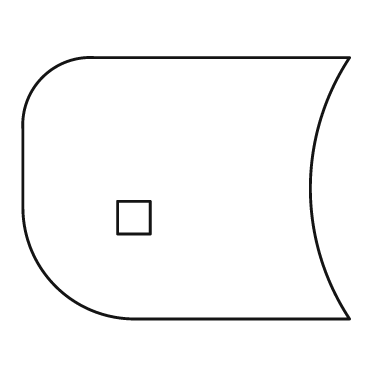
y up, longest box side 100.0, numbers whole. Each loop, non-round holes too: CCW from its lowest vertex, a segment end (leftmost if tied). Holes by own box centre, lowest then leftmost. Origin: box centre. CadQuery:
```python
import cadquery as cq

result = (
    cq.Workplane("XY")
    .moveTo(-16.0, -40.0)
    .lineTo(50.0, -40.0)
    .threePointArc((38.0, 0.0), (50.0, 40.0))
    .lineTo(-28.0, 40.0)
    .threePointArc((-44.0, 34.0), (-50.0, 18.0))
    .lineTo(-50.0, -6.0)
    .threePointArc((-40.0, -30.0), (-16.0, -40.0))
    .close()
    .moveTo(-21.0, -14.0)
    .lineTo(-11.0, -14.0)
    .lineTo(-11.0, -4.0)
    .lineTo(-21.0, -4.0)
    .close()
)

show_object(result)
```